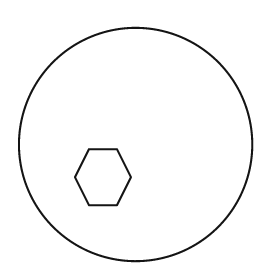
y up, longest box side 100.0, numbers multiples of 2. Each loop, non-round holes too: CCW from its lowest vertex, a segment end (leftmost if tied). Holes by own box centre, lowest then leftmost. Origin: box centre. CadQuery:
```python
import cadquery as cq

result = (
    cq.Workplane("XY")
    .moveTo(0.0, 0.0)
    .circle(50.0)
    .moveTo(-20.0, -26.0)
    .lineTo(-8.0, -26.0)
    .lineTo(-2.0, -14.0)
    .lineTo(-8.0, -2.0)
    .lineTo(-20.0, -2.0)
    .lineTo(-26.0, -14.0)
    .close()
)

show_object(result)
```